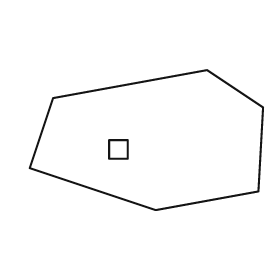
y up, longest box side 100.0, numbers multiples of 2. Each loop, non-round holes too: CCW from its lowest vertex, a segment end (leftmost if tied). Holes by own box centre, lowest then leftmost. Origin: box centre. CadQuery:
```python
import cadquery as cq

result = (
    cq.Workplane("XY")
    .moveTo(4.0, -30.0)
    .lineTo(48.0, -22.0)
    .lineTo(50.0, 14.0)
    .lineTo(26.0, 30.0)
    .lineTo(-40.0, 18.0)
    .lineTo(-50.0, -12.0)
    .close()
    .moveTo(-16.0, -8.0)
    .lineTo(-8.0, -8.0)
    .lineTo(-8.0, 0.0)
    .lineTo(-16.0, 0.0)
    .close()
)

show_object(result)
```